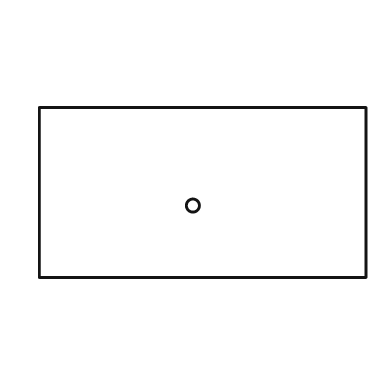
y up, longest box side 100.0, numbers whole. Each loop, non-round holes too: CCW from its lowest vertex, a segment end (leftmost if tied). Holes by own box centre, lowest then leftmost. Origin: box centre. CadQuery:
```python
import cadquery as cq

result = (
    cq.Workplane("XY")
    .moveTo(-50.0, -26.0)
    .lineTo(50.0, -26.0)
    .lineTo(50.0, 26.0)
    .lineTo(-50.0, 26.0)
    .close()
    .moveTo(-3.0, -4.0)
    .circle(2.0)
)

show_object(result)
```